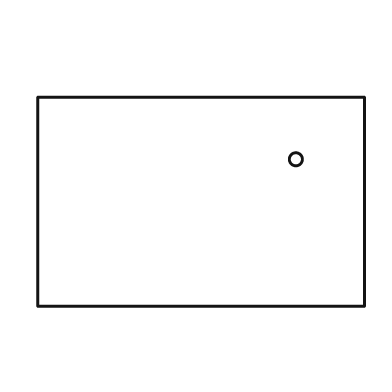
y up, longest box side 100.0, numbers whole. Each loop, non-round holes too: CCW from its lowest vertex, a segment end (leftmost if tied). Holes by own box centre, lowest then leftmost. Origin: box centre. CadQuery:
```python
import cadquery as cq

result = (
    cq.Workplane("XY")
    .moveTo(-50.0, -32.0)
    .lineTo(50.0, -32.0)
    .lineTo(50.0, 32.0)
    .lineTo(-50.0, 32.0)
    .close()
    .moveTo(29.0, 13.0)
    .circle(2.0)
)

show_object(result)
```